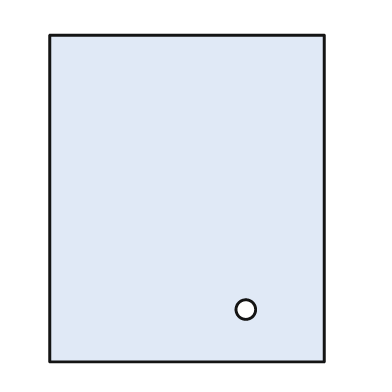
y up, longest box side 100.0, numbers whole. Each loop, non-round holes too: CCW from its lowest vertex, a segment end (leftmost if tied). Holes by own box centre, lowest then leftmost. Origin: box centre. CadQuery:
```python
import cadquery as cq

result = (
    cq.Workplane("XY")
    .moveTo(-42.0, -50.0)
    .lineTo(42.0, -50.0)
    .lineTo(42.0, 50.0)
    .lineTo(-42.0, 50.0)
    .close()
    .moveTo(18.0, -34.0)
    .circle(3.0)
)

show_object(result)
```